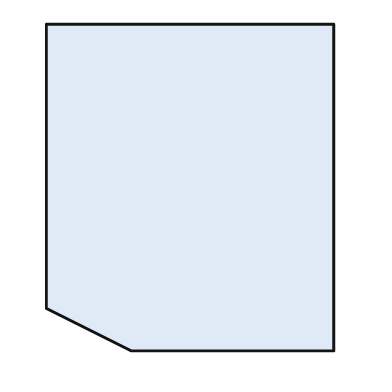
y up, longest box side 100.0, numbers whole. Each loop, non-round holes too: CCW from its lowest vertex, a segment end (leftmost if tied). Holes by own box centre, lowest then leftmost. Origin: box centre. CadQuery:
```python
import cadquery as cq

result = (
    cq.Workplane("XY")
    .moveTo(-18.0, -50.0)
    .lineTo(44.0, -50.0)
    .lineTo(44.0, 50.0)
    .lineTo(-44.0, 50.0)
    .lineTo(-44.0, -37.0)
    .close()
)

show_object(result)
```